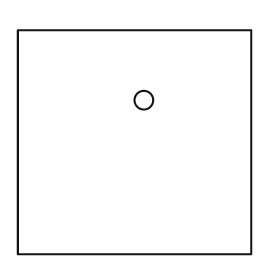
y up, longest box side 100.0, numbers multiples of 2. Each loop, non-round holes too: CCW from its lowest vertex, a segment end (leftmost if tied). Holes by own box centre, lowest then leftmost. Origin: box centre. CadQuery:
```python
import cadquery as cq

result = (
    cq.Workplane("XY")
    .moveTo(-50.0, -48.0)
    .lineTo(50.0, -48.0)
    .lineTo(50.0, 48.0)
    .lineTo(-50.0, 48.0)
    .close()
    .moveTo(4.0, 18.0)
    .circle(4.0)
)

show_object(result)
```